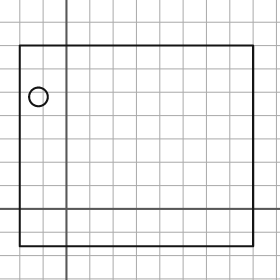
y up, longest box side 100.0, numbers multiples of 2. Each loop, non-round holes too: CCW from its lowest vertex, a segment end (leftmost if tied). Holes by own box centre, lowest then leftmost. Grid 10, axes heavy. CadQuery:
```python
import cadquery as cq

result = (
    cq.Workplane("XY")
    .moveTo(-20.0, -16.0)
    .lineTo(80.0, -16.0)
    .lineTo(80.0, 70.0)
    .lineTo(-20.0, 70.0)
    .close()
    .moveTo(-12.0, 48.0)
    .circle(4.0)
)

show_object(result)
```